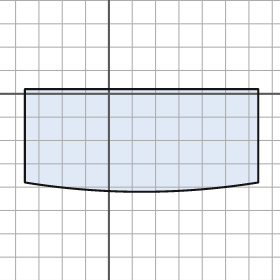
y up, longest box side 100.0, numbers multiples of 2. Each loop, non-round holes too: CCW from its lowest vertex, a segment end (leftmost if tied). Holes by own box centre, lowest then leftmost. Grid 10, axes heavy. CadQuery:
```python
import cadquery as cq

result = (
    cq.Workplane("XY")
    .moveTo(-36.0, -38.0)
    .threePointArc((14.0, -42.0), (64.0, -38.0))
    .lineTo(64.0, 2.0)
    .lineTo(-36.0, 2.0)
    .close()
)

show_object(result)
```